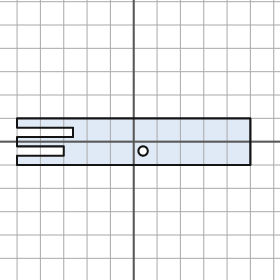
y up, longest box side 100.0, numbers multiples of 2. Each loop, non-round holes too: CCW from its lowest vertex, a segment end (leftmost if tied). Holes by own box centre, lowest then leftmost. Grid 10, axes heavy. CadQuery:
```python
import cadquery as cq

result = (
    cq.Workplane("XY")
    .moveTo(-50.0, -10.0)
    .lineTo(50.0, -10.0)
    .lineTo(50.0, 10.0)
    .lineTo(-50.0, 10.0)
    .lineTo(-50.0, 6.0)
    .lineTo(-26.0, 6.0)
    .lineTo(-26.0, 2.0)
    .lineTo(-50.0, 2.0)
    .lineTo(-50.0, -2.0)
    .lineTo(-30.0, -2.0)
    .lineTo(-30.0, -6.0)
    .lineTo(-50.0, -6.0)
    .close()
    .moveTo(4.0, -4.0)
    .circle(2.0)
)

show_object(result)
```